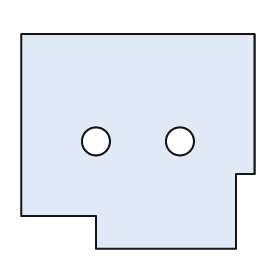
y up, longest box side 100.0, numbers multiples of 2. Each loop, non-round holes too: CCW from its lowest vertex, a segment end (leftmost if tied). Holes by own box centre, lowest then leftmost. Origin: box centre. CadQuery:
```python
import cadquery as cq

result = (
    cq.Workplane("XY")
    .moveTo(-18.0, -46.0)
    .lineTo(42.0, -46.0)
    .lineTo(42.0, -14.0)
    .lineTo(50.0, -14.0)
    .lineTo(50.0, 46.0)
    .lineTo(-50.0, 46.0)
    .lineTo(-50.0, -32.0)
    .lineTo(-18.0, -32.0)
    .close()
    .moveTo(-18.0, 0.0)
    .circle(6.0)
    .moveTo(18.0, 0.0)
    .circle(6.0)
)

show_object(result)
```